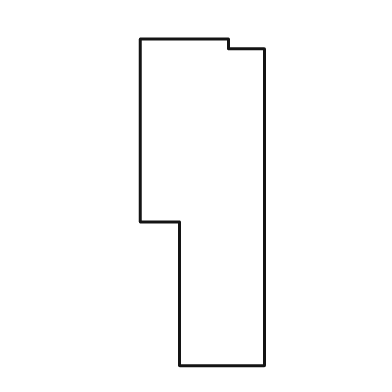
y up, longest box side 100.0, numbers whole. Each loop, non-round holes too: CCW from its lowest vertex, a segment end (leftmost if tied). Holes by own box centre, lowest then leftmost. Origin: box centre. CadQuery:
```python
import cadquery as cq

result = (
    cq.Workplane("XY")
    .moveTo(-7.0, -50.0)
    .lineTo(19.0, -50.0)
    .lineTo(19.0, 47.0)
    .lineTo(8.0, 47.0)
    .lineTo(8.0, 50.0)
    .lineTo(-19.0, 50.0)
    .lineTo(-19.0, -6.0)
    .lineTo(-7.0, -6.0)
    .close()
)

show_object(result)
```